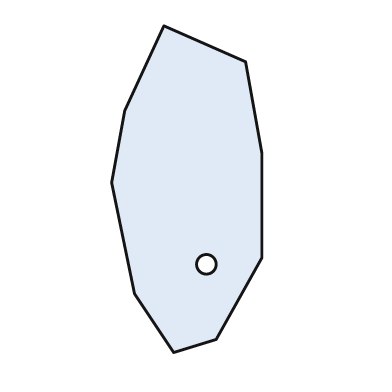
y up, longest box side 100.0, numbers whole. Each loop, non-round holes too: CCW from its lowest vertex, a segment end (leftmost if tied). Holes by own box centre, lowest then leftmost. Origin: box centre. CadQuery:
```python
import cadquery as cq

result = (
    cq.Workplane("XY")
    .moveTo(-4.0, -50.0)
    .lineTo(9.0, -46.0)
    .lineTo(23.0, -21.0)
    .lineTo(23.0, 11.0)
    .lineTo(18.0, 39.0)
    .lineTo(-7.0, 50.0)
    .lineTo(-19.0, 24.0)
    .lineTo(-23.0, 2.0)
    .lineTo(-16.0, -32.0)
    .close()
    .moveTo(6.0, -23.0)
    .circle(3.0)
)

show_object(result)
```